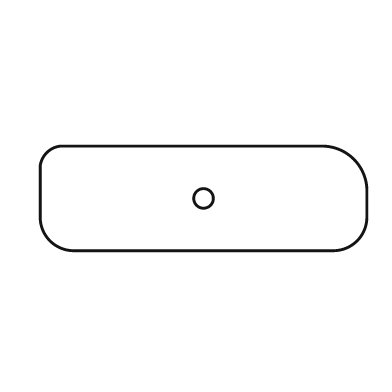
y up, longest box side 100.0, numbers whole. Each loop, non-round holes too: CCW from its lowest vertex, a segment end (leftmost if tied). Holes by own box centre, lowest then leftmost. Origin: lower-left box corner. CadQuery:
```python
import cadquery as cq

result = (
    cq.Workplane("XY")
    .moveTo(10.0, 0.0)
    .lineTo(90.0, 0.0)
    .threePointArc((97.0, 3.0), (100.0, 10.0))
    .lineTo(100.0, 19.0)
    .threePointArc((96.0, 28.0), (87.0, 32.0))
    .lineTo(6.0, 32.0)
    .threePointArc((2.0, 30.0), (0.0, 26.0))
    .lineTo(0.0, 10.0)
    .threePointArc((3.0, 3.0), (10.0, 0.0))
    .close()
    .moveTo(50.0, 16.0)
    .circle(3.0)
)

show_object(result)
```